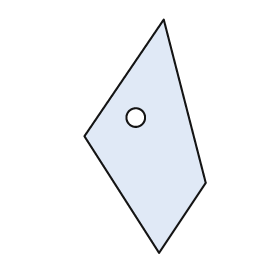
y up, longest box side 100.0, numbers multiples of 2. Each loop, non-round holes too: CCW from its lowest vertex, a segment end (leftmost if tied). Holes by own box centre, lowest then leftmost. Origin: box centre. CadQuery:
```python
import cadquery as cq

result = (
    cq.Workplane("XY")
    .moveTo(6.0, -50.0)
    .lineTo(26.0, -20.0)
    .lineTo(8.0, 50.0)
    .lineTo(-26.0, 0.0)
    .close()
    .moveTo(-4.0, 8.0)
    .circle(4.0)
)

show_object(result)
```